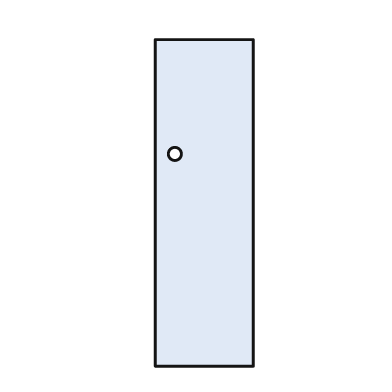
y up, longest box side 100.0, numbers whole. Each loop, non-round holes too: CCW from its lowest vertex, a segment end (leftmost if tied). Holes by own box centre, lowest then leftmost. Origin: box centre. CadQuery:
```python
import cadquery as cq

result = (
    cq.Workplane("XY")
    .moveTo(-15.0, -50.0)
    .lineTo(15.0, -50.0)
    .lineTo(15.0, 50.0)
    .lineTo(-15.0, 50.0)
    .close()
    .moveTo(-9.0, 15.0)
    .circle(2.0)
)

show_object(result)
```